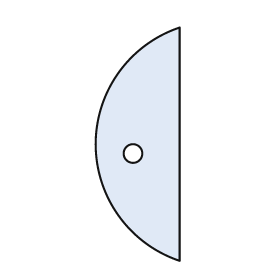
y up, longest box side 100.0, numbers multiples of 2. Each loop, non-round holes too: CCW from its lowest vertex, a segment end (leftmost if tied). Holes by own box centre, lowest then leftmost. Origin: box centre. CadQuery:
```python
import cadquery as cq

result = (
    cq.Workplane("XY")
    .moveTo(18.0, -50.0)
    .lineTo(18.0, 50.0)
    .threePointArc((-18.0, 0.0), (18.0, -50.0))
    .close()
    .moveTo(-2.0, -4.0)
    .circle(4.0)
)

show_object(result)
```